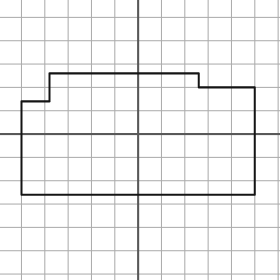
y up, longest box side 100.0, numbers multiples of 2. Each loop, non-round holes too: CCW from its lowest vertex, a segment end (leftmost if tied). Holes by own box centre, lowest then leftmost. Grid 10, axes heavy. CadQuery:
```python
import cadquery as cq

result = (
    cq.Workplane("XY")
    .moveTo(-50.0, -26.0)
    .lineTo(50.0, -26.0)
    .lineTo(50.0, 20.0)
    .lineTo(26.0, 20.0)
    .lineTo(26.0, 26.0)
    .lineTo(-38.0, 26.0)
    .lineTo(-38.0, 14.0)
    .lineTo(-50.0, 14.0)
    .close()
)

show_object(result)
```